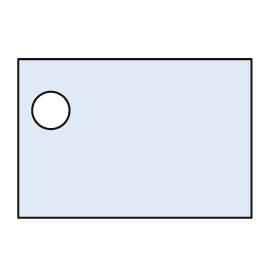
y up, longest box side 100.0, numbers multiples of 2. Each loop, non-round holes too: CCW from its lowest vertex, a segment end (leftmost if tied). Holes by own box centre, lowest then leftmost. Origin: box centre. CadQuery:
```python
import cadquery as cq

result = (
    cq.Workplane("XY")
    .moveTo(-50.0, -34.0)
    .lineTo(50.0, -34.0)
    .lineTo(50.0, 34.0)
    .lineTo(-50.0, 34.0)
    .close()
    .moveTo(-36.0, 12.0)
    .circle(8.0)
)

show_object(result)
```